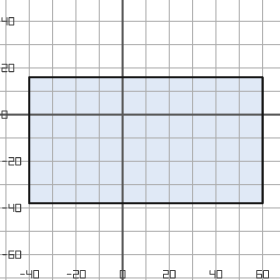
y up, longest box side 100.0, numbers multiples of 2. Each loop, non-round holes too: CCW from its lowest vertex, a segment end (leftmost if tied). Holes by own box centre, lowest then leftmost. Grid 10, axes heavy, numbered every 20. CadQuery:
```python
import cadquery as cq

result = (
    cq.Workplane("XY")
    .moveTo(-40.0, -38.0)
    .lineTo(60.0, -38.0)
    .lineTo(60.0, 16.0)
    .lineTo(-40.0, 16.0)
    .close()
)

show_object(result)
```